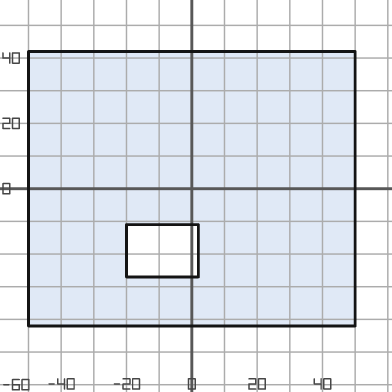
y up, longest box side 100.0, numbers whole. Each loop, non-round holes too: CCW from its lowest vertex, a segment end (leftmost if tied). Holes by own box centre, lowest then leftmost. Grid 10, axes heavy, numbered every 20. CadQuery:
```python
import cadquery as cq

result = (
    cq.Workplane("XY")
    .moveTo(-50.0, -42.0)
    .lineTo(50.0, -42.0)
    .lineTo(50.0, 42.0)
    .lineTo(-50.0, 42.0)
    .close()
    .moveTo(-20.0, -27.0)
    .lineTo(2.0, -27.0)
    .lineTo(2.0, -11.0)
    .lineTo(-20.0, -11.0)
    .close()
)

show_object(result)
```